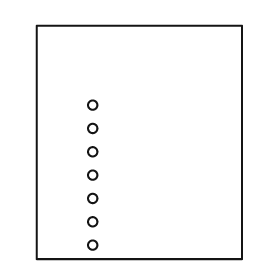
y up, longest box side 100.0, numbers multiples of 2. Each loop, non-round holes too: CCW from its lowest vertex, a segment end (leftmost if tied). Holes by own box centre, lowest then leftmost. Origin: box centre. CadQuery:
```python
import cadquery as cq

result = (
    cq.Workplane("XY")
    .moveTo(-44.0, -50.0)
    .lineTo(44.0, -50.0)
    .lineTo(44.0, 50.0)
    .lineTo(-44.0, 50.0)
    .close()
    .moveTo(-20.0, -44.0)
    .circle(2.0)
    .moveTo(-20.0, -34.0)
    .circle(2.0)
    .moveTo(-20.0, -24.0)
    .circle(2.0)
    .moveTo(-20.0, -14.0)
    .circle(2.0)
    .moveTo(-20.0, -4.0)
    .circle(2.0)
    .moveTo(-20.0, 6.0)
    .circle(2.0)
    .moveTo(-20.0, 16.0)
    .circle(2.0)
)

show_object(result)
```